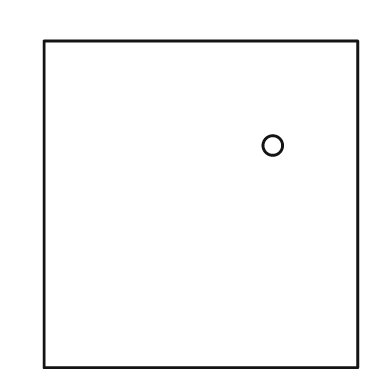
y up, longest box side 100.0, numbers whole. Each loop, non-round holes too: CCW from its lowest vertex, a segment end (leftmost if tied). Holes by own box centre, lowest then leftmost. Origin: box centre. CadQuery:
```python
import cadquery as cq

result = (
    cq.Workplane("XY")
    .moveTo(-48.0, -50.0)
    .lineTo(48.0, -50.0)
    .lineTo(48.0, 50.0)
    .lineTo(-48.0, 50.0)
    .close()
    .moveTo(22.0, 18.0)
    .circle(3.0)
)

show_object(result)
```